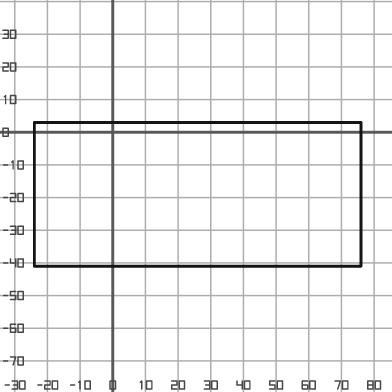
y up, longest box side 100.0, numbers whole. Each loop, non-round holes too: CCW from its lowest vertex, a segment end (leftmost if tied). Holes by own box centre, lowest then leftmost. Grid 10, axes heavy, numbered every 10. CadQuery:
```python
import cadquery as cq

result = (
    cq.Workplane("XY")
    .moveTo(-24.0, -41.0)
    .lineTo(76.0, -41.0)
    .lineTo(76.0, 3.0)
    .lineTo(-24.0, 3.0)
    .close()
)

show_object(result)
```